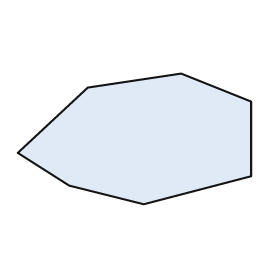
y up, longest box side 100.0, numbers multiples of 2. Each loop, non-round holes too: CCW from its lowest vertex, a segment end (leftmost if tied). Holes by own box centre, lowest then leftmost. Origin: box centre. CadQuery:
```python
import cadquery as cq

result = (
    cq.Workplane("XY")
    .moveTo(4.0, -28.0)
    .lineTo(50.0, -16.0)
    .lineTo(50.0, 16.0)
    .lineTo(20.0, 28.0)
    .lineTo(-20.0, 22.0)
    .lineTo(-50.0, -6.0)
    .lineTo(-28.0, -20.0)
    .close()
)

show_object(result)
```